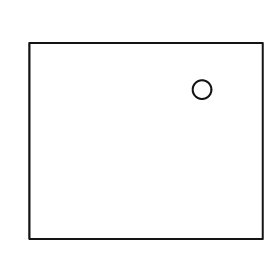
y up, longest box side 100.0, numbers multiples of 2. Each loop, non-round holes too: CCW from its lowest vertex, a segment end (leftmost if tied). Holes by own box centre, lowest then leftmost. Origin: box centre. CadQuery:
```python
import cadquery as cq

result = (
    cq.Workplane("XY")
    .moveTo(-50.0, -42.0)
    .lineTo(50.0, -42.0)
    .lineTo(50.0, 42.0)
    .lineTo(-50.0, 42.0)
    .close()
    .moveTo(24.0, 22.0)
    .circle(4.0)
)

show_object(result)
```